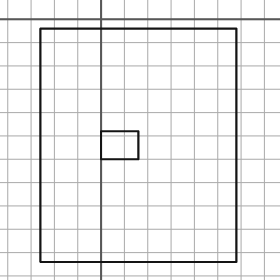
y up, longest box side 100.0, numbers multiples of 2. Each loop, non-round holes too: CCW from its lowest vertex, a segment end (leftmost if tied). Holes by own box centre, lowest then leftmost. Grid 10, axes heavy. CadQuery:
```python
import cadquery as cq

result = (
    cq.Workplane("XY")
    .moveTo(-26.0, -104.0)
    .lineTo(58.0, -104.0)
    .lineTo(58.0, -4.0)
    .lineTo(-26.0, -4.0)
    .close()
    .moveTo(0.0, -60.0)
    .lineTo(16.0, -60.0)
    .lineTo(16.0, -48.0)
    .lineTo(0.0, -48.0)
    .close()
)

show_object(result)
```